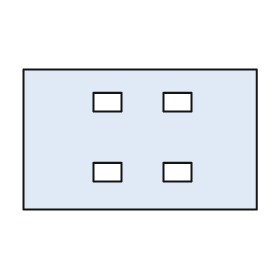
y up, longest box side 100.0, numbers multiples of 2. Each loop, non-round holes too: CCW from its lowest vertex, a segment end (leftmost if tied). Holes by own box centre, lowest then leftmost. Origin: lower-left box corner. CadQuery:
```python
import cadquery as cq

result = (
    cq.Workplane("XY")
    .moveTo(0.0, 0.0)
    .lineTo(100.0, 0.0)
    .lineTo(100.0, 60.0)
    .lineTo(0.0, 60.0)
    .close()
    .moveTo(30.0, 12.0)
    .lineTo(42.0, 12.0)
    .lineTo(42.0, 20.0)
    .lineTo(30.0, 20.0)
    .close()
    .moveTo(60.0, 12.0)
    .lineTo(72.0, 12.0)
    .lineTo(72.0, 20.0)
    .lineTo(60.0, 20.0)
    .close()
    .moveTo(30.0, 42.0)
    .lineTo(42.0, 42.0)
    .lineTo(42.0, 50.0)
    .lineTo(30.0, 50.0)
    .close()
    .moveTo(60.0, 42.0)
    .lineTo(72.0, 42.0)
    .lineTo(72.0, 50.0)
    .lineTo(60.0, 50.0)
    .close()
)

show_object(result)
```